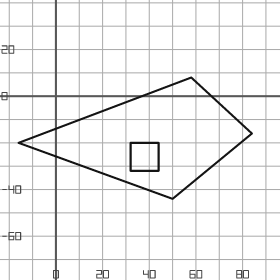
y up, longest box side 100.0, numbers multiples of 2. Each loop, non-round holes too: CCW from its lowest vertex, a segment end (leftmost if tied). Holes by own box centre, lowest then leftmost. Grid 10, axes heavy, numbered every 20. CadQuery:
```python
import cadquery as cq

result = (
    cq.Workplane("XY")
    .moveTo(50.0, -44.0)
    .lineTo(84.0, -16.0)
    .lineTo(58.0, 8.0)
    .lineTo(-16.0, -20.0)
    .close()
    .moveTo(32.0, -32.0)
    .lineTo(44.0, -32.0)
    .lineTo(44.0, -20.0)
    .lineTo(32.0, -20.0)
    .close()
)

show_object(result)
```